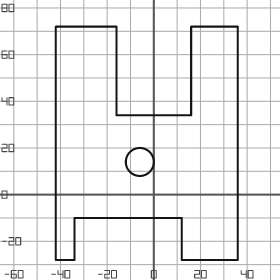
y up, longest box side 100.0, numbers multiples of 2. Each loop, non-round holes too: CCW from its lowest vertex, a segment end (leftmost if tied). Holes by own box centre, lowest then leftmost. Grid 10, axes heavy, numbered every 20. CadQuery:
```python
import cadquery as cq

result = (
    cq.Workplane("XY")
    .moveTo(-42.0, -28.0)
    .lineTo(-34.0, -28.0)
    .lineTo(-34.0, -10.0)
    .lineTo(12.0, -10.0)
    .lineTo(12.0, -28.0)
    .lineTo(36.0, -28.0)
    .lineTo(36.0, 72.0)
    .lineTo(16.0, 72.0)
    .lineTo(16.0, 34.0)
    .lineTo(-16.0, 34.0)
    .lineTo(-16.0, 72.0)
    .lineTo(-42.0, 72.0)
    .close()
    .moveTo(-6.0, 14.0)
    .circle(6.0)
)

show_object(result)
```